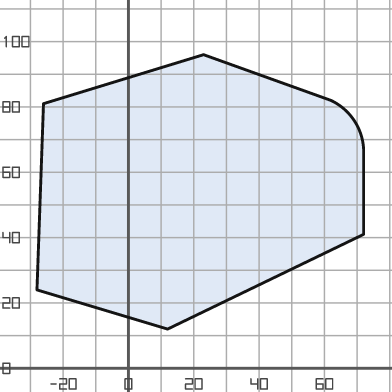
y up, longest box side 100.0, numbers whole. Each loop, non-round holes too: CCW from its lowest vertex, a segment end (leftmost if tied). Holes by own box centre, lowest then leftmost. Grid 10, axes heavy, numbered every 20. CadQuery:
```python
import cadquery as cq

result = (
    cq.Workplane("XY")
    .moveTo(12.0, 12.0)
    .lineTo(72.0, 41.0)
    .lineTo(72.0, 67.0)
    .threePointArc((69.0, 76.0), (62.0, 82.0))
    .lineTo(23.0, 96.0)
    .lineTo(-26.0, 81.0)
    .lineTo(-28.0, 24.0)
    .close()
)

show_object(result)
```